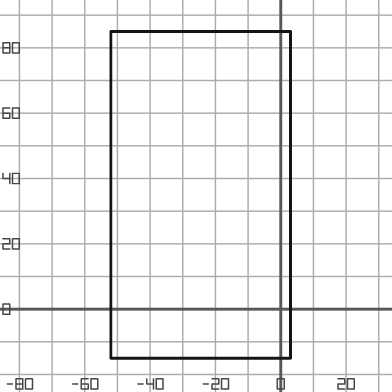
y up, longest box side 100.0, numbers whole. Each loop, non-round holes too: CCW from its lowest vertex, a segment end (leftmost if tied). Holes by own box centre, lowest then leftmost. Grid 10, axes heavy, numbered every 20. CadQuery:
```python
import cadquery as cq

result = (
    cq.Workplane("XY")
    .moveTo(-52.0, -15.0)
    .lineTo(3.0, -15.0)
    .lineTo(3.0, 85.0)
    .lineTo(-52.0, 85.0)
    .close()
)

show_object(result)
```